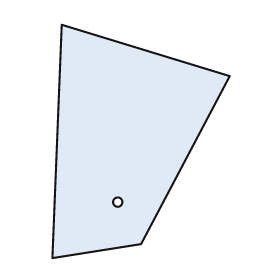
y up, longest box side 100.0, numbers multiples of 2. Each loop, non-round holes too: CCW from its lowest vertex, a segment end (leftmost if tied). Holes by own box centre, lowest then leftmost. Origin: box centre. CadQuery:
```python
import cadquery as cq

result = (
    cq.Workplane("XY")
    .moveTo(-38.0, -50.0)
    .lineTo(0.0, -44.0)
    .lineTo(38.0, 28.0)
    .lineTo(-34.0, 50.0)
    .close()
    .moveTo(-10.0, -26.0)
    .circle(2.0)
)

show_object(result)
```